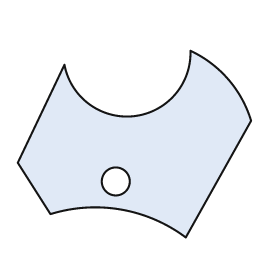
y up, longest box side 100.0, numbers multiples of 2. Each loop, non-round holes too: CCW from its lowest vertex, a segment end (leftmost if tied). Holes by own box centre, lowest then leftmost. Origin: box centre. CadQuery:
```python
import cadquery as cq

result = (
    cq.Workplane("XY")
    .moveTo(22.0, -40.0)
    .lineTo(50.0, 10.0)
    .threePointArc((40.0, 28.0), (24.0, 40.0))
    .threePointArc((0.0, 12.0), (-30.0, 34.0))
    .lineTo(-50.0, -8.0)
    .lineTo(-36.0, -30.0)
    .threePointArc((-6.0, -28.0), (22.0, -40.0))
    .close()
    .moveTo(-8.0, -16.0)
    .circle(6.0)
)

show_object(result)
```